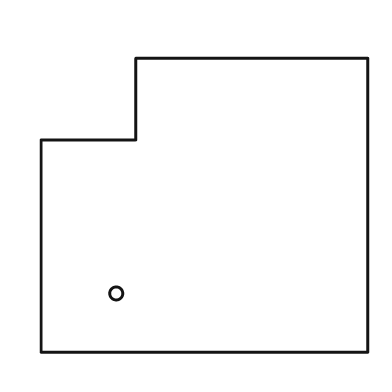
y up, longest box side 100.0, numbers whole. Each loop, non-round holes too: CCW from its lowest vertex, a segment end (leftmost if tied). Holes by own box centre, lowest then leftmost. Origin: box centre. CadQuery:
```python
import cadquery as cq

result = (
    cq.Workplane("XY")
    .moveTo(-50.0, -45.0)
    .lineTo(50.0, -45.0)
    .lineTo(50.0, 45.0)
    .lineTo(-21.0, 45.0)
    .lineTo(-21.0, 20.0)
    .lineTo(-50.0, 20.0)
    .close()
    .moveTo(-27.0, -27.0)
    .circle(2.0)
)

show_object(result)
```